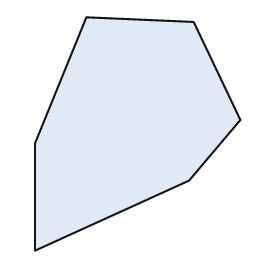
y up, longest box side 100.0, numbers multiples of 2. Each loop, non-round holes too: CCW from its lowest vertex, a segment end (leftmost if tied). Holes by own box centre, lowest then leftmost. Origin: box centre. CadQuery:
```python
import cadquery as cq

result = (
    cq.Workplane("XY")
    .moveTo(-44.0, -50.0)
    .lineTo(22.0, -20.0)
    .lineTo(44.0, 6.0)
    .lineTo(24.0, 48.0)
    .lineTo(-22.0, 50.0)
    .lineTo(-44.0, -4.0)
    .close()
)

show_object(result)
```